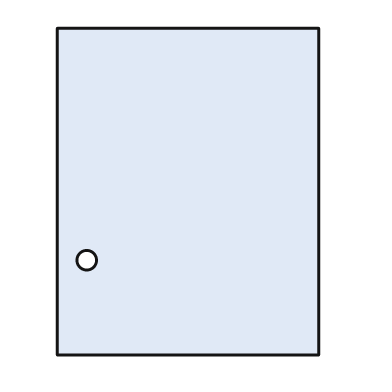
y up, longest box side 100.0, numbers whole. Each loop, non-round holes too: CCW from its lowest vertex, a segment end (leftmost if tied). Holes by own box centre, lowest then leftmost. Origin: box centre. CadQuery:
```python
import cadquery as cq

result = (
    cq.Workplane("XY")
    .moveTo(-40.0, -50.0)
    .lineTo(40.0, -50.0)
    .lineTo(40.0, 50.0)
    .lineTo(-40.0, 50.0)
    .close()
    .moveTo(-31.0, -21.0)
    .circle(3.0)
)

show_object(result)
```